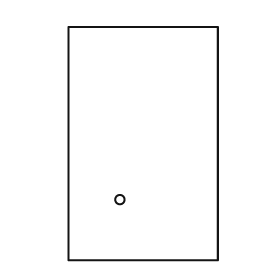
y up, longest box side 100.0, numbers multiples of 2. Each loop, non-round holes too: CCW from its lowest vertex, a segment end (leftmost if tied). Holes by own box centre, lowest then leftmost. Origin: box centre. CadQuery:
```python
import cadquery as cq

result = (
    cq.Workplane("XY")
    .moveTo(-32.0, -50.0)
    .lineTo(32.0, -50.0)
    .lineTo(32.0, 50.0)
    .lineTo(-32.0, 50.0)
    .close()
    .moveTo(-10.0, -24.0)
    .circle(2.0)
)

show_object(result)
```